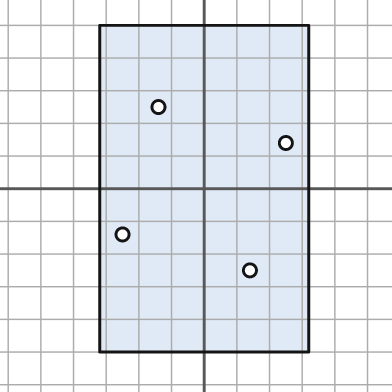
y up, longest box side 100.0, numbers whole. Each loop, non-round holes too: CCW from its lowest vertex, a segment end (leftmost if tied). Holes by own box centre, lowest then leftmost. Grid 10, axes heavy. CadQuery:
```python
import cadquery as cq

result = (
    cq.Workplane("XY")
    .moveTo(-32.0, -50.0)
    .lineTo(32.0, -50.0)
    .lineTo(32.0, 50.0)
    .lineTo(-32.0, 50.0)
    .close()
    .moveTo(14.0, -25.0)
    .circle(2.0)
    .moveTo(-25.0, -14.0)
    .circle(2.0)
    .moveTo(25.0, 14.0)
    .circle(2.0)
    .moveTo(-14.0, 25.0)
    .circle(2.0)
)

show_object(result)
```